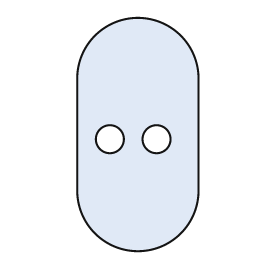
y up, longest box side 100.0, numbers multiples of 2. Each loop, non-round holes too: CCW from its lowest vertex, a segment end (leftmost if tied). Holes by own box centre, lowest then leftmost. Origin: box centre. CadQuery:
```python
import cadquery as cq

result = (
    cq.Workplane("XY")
    .moveTo(-26.0, -24.0)
    .threePointArc((0.0, -50.0), (26.0, -24.0))
    .lineTo(26.0, 24.0)
    .threePointArc((0.0, 50.0), (-26.0, 24.0))
    .close()
    .moveTo(-12.0, -2.0)
    .circle(6.0)
    .moveTo(8.0, -2.0)
    .circle(6.0)
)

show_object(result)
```